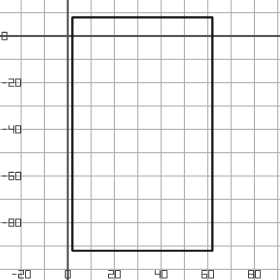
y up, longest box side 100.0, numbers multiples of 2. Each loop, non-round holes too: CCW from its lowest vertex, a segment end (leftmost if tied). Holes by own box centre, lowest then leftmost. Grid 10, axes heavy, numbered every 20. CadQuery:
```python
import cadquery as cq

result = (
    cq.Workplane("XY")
    .moveTo(2.0, -92.0)
    .lineTo(62.0, -92.0)
    .lineTo(62.0, 8.0)
    .lineTo(2.0, 8.0)
    .close()
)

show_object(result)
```